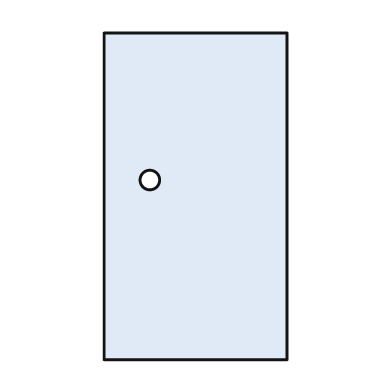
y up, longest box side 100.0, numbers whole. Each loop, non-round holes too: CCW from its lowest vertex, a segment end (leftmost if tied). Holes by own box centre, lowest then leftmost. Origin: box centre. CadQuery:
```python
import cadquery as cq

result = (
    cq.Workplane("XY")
    .moveTo(-28.0, -50.0)
    .lineTo(28.0, -50.0)
    .lineTo(28.0, 50.0)
    .lineTo(-28.0, 50.0)
    .close()
    .moveTo(-14.0, 5.0)
    .circle(3.0)
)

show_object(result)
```